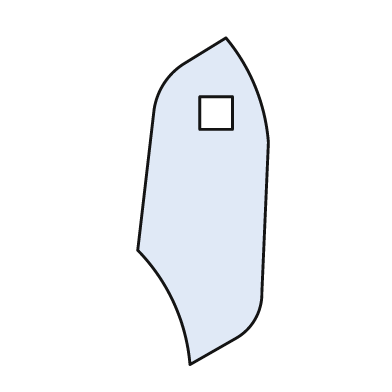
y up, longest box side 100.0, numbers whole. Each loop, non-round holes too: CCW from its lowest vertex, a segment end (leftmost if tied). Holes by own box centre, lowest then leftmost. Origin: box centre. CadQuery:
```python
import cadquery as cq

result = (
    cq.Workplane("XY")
    .moveTo(-4.0, -50.0)
    .lineTo(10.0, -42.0)
    .threePointArc((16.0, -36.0), (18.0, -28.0))
    .lineTo(20.0, 18.0)
    .threePointArc((16.0, 35.0), (7.0, 50.0))
    .lineTo(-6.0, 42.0)
    .threePointArc((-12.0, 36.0), (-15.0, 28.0))
    .lineTo(-20.0, -15.0)
    .threePointArc((-9.0, -31.0), (-4.0, -50.0))
    .close()
    .moveTo(-1.0, 22.0)
    .lineTo(9.0, 22.0)
    .lineTo(9.0, 32.0)
    .lineTo(-1.0, 32.0)
    .close()
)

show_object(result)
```